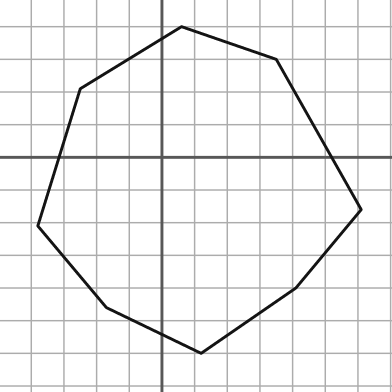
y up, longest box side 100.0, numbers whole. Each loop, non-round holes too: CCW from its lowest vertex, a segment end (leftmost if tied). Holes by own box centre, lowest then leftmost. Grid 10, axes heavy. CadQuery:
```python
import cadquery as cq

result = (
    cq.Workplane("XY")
    .moveTo(12.0, -60.0)
    .lineTo(41.0, -40.0)
    .lineTo(61.0, -16.0)
    .lineTo(35.0, 30.0)
    .lineTo(6.0, 40.0)
    .lineTo(-25.0, 21.0)
    .lineTo(-38.0, -21.0)
    .lineTo(-17.0, -46.0)
    .close()
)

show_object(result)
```